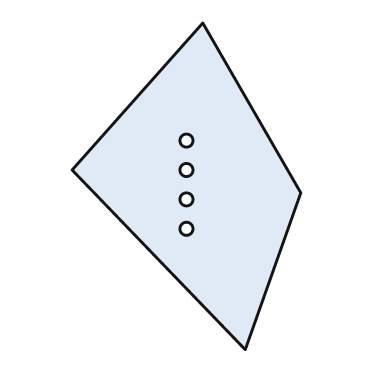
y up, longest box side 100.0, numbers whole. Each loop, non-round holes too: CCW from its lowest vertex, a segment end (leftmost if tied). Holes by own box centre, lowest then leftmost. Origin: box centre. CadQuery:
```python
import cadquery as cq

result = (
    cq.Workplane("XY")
    .moveTo(18.0, -50.0)
    .lineTo(35.0, -2.0)
    .lineTo(5.0, 50.0)
    .lineTo(-35.0, 5.0)
    .close()
    .moveTo(0.0, -13.0)
    .circle(2.0)
    .moveTo(0.0, -4.0)
    .circle(2.0)
    .moveTo(0.0, 5.0)
    .circle(2.0)
    .moveTo(0.0, 14.0)
    .circle(2.0)
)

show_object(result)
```